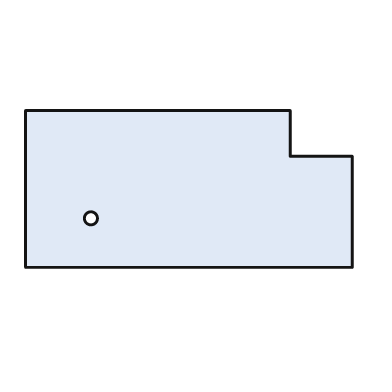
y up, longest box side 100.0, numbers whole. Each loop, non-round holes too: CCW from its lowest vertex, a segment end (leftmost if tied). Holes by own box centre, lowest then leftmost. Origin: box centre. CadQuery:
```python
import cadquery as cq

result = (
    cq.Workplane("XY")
    .moveTo(-50.0, -24.0)
    .lineTo(50.0, -24.0)
    .lineTo(50.0, 10.0)
    .lineTo(31.0, 10.0)
    .lineTo(31.0, 24.0)
    .lineTo(-50.0, 24.0)
    .close()
    .moveTo(-30.0, -9.0)
    .circle(2.0)
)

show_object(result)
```